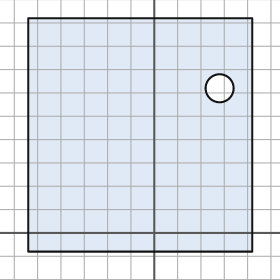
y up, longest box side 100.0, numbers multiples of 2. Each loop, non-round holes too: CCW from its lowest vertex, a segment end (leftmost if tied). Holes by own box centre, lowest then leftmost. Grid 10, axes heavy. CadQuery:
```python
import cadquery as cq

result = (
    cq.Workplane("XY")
    .moveTo(-54.0, -8.0)
    .lineTo(42.0, -8.0)
    .lineTo(42.0, 92.0)
    .lineTo(-54.0, 92.0)
    .close()
    .moveTo(28.0, 62.0)
    .circle(6.0)
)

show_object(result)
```